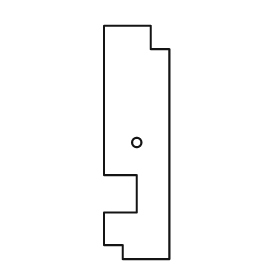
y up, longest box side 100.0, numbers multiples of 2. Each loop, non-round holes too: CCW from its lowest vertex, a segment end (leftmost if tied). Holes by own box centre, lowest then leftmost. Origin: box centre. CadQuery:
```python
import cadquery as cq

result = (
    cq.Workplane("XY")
    .moveTo(-6.0, -50.0)
    .lineTo(14.0, -50.0)
    .lineTo(14.0, 40.0)
    .lineTo(6.0, 40.0)
    .lineTo(6.0, 50.0)
    .lineTo(-14.0, 50.0)
    .lineTo(-14.0, -14.0)
    .lineTo(0.0, -14.0)
    .lineTo(0.0, -30.0)
    .lineTo(-14.0, -30.0)
    .lineTo(-14.0, -44.0)
    .lineTo(-6.0, -44.0)
    .close()
    .moveTo(0.0, 0.0)
    .circle(2.0)
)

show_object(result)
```